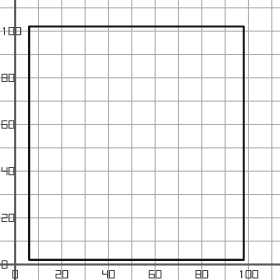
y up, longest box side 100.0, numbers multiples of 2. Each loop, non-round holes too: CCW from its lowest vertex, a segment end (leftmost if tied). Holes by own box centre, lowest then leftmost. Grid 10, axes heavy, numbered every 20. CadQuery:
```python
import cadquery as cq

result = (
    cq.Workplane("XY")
    .moveTo(6.0, 2.0)
    .lineTo(98.0, 2.0)
    .lineTo(98.0, 102.0)
    .lineTo(6.0, 102.0)
    .close()
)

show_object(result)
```